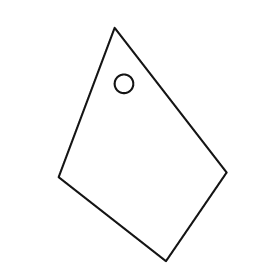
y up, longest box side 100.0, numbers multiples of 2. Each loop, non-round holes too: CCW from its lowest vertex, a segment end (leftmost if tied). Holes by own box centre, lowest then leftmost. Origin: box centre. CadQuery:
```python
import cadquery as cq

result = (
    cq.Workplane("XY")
    .moveTo(10.0, -50.0)
    .lineTo(36.0, -12.0)
    .lineTo(-12.0, 50.0)
    .lineTo(-36.0, -14.0)
    .close()
    .moveTo(-8.0, 26.0)
    .circle(4.0)
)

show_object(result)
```